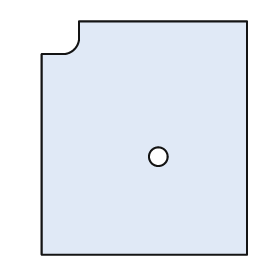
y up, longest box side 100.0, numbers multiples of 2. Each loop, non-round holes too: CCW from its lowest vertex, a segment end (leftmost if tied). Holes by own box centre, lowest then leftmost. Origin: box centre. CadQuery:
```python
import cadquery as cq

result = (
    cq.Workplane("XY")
    .moveTo(-44.0, -50.0)
    .lineTo(44.0, -50.0)
    .lineTo(44.0, 50.0)
    .lineTo(-28.0, 50.0)
    .lineTo(-28.0, 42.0)
    .threePointArc((-30.0, 38.0), (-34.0, 36.0))
    .lineTo(-44.0, 36.0)
    .close()
    .moveTo(6.0, -8.0)
    .circle(4.0)
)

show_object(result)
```